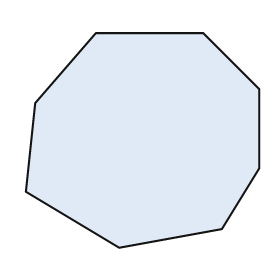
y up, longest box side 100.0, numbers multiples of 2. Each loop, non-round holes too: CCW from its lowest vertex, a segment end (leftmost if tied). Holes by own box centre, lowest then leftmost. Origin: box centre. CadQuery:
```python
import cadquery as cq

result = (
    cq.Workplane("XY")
    .moveTo(-10.0, -46.0)
    .lineTo(34.0, -38.0)
    .lineTo(50.0, -12.0)
    .lineTo(50.0, 22.0)
    .lineTo(26.0, 46.0)
    .lineTo(-20.0, 46.0)
    .lineTo(-46.0, 16.0)
    .lineTo(-50.0, -22.0)
    .close()
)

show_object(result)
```